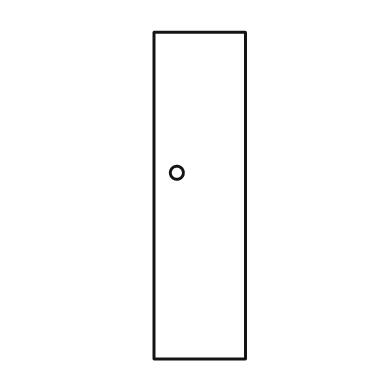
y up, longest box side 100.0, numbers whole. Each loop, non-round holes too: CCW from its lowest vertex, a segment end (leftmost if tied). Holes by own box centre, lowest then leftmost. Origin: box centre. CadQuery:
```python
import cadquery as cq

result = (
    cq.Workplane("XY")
    .moveTo(-14.0, -50.0)
    .lineTo(14.0, -50.0)
    .lineTo(14.0, 50.0)
    .lineTo(-14.0, 50.0)
    .close()
    .moveTo(-7.0, 7.0)
    .circle(2.0)
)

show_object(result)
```